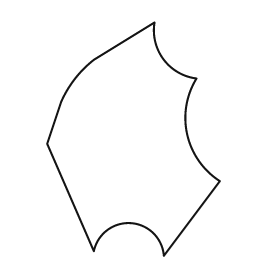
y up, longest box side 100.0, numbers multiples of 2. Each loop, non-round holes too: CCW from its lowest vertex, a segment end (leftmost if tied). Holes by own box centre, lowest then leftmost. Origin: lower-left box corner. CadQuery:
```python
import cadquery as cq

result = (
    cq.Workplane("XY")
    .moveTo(50.0, 0.0)
    .lineTo(74.0, 32.0)
    .threePointArc((60.0, 52.0), (64.0, 76.0))
    .threePointArc((50.0, 84.0), (46.0, 100.0))
    .lineTo(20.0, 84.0)
    .threePointArc((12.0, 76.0), (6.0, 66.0))
    .lineTo(0.0, 48.0)
    .lineTo(20.0, 2.0)
    .threePointArc((36.0, 14.0), (50.0, 0.0))
    .close()
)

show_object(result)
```